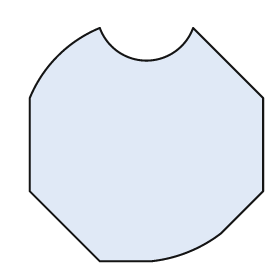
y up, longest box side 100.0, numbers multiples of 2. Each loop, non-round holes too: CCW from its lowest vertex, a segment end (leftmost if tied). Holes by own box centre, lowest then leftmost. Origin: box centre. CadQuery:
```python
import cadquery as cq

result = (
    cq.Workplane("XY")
    .moveTo(-20.0, -50.0)
    .lineTo(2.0, -50.0)
    .threePointArc((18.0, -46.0), (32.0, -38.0))
    .lineTo(50.0, -20.0)
    .lineTo(50.0, 20.0)
    .lineTo(20.0, 50.0)
    .threePointArc((0.0, 36.0), (-20.0, 50.0))
    .threePointArc((-38.0, 38.0), (-50.0, 20.0))
    .lineTo(-50.0, -20.0)
    .close()
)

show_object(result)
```